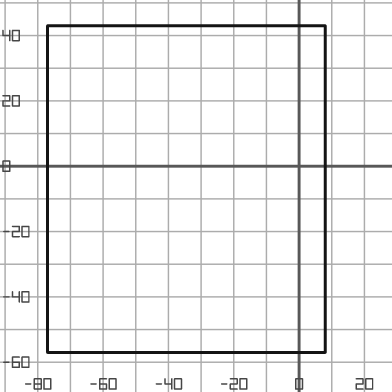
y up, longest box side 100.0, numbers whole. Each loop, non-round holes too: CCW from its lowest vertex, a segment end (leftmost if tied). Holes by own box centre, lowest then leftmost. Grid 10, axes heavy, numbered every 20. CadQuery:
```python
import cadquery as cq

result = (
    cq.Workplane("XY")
    .moveTo(-77.0, -57.0)
    .lineTo(8.0, -57.0)
    .lineTo(8.0, 43.0)
    .lineTo(-77.0, 43.0)
    .close()
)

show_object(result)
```